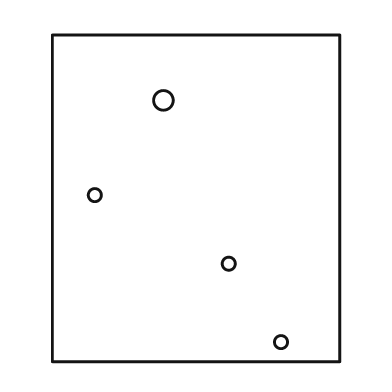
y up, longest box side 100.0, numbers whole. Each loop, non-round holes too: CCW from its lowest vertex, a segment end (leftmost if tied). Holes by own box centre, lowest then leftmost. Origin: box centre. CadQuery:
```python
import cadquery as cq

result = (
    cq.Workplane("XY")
    .moveTo(-44.0, -50.0)
    .lineTo(44.0, -50.0)
    .lineTo(44.0, 50.0)
    .lineTo(-44.0, 50.0)
    .close()
    .moveTo(26.0, -44.0)
    .circle(2.0)
    .moveTo(10.0, -20.0)
    .circle(2.0)
    .moveTo(-31.0, 1.0)
    .circle(2.0)
    .moveTo(-10.0, 30.0)
    .circle(3.0)
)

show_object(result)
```